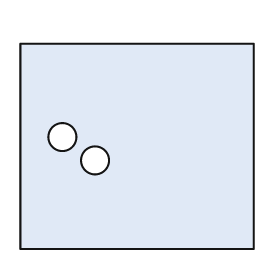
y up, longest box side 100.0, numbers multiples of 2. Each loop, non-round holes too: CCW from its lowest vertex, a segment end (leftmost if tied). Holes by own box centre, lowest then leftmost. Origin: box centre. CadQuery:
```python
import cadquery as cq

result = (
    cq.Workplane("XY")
    .moveTo(-50.0, -44.0)
    .lineTo(50.0, -44.0)
    .lineTo(50.0, 44.0)
    .lineTo(-50.0, 44.0)
    .close()
    .moveTo(-18.0, -6.0)
    .circle(6.0)
    .moveTo(-32.0, 4.0)
    .circle(6.0)
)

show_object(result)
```